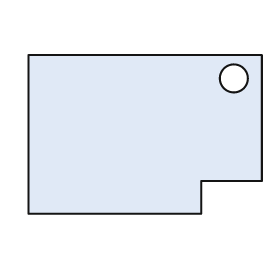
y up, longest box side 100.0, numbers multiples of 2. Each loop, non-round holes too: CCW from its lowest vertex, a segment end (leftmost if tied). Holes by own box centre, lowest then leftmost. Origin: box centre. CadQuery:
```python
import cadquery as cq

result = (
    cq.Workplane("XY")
    .moveTo(-50.0, -34.0)
    .lineTo(24.0, -34.0)
    .lineTo(24.0, -20.0)
    .lineTo(50.0, -20.0)
    .lineTo(50.0, 34.0)
    .lineTo(-50.0, 34.0)
    .close()
    .moveTo(38.0, 24.0)
    .circle(6.0)
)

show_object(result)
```